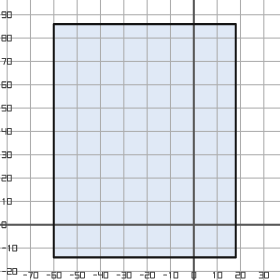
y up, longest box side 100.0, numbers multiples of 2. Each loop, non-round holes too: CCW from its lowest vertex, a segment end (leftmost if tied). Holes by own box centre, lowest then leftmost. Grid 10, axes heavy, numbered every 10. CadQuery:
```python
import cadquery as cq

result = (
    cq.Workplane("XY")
    .moveTo(-60.0, -14.0)
    .lineTo(18.0, -14.0)
    .lineTo(18.0, 86.0)
    .lineTo(-60.0, 86.0)
    .close()
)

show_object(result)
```